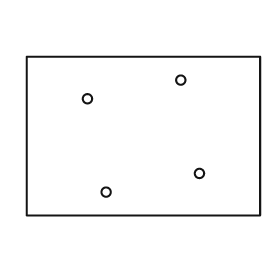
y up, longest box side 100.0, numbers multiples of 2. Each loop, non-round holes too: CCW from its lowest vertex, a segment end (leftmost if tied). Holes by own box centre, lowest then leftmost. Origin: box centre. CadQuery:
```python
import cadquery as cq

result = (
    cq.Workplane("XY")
    .moveTo(-50.0, -34.0)
    .lineTo(50.0, -34.0)
    .lineTo(50.0, 34.0)
    .lineTo(-50.0, 34.0)
    .close()
    .moveTo(-16.0, -24.0)
    .circle(2.0)
    .moveTo(24.0, -16.0)
    .circle(2.0)
    .moveTo(-24.0, 16.0)
    .circle(2.0)
    .moveTo(16.0, 24.0)
    .circle(2.0)
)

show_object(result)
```